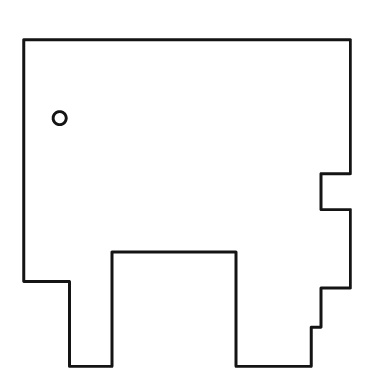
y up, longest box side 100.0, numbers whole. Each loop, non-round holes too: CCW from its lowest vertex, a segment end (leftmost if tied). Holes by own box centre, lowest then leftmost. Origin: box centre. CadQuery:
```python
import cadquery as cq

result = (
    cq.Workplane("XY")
    .moveTo(-36.0, -50.0)
    .lineTo(-23.0, -50.0)
    .lineTo(-23.0, -15.0)
    .lineTo(15.0, -15.0)
    .lineTo(15.0, -50.0)
    .lineTo(38.0, -50.0)
    .lineTo(38.0, -38.0)
    .lineTo(41.0, -38.0)
    .lineTo(41.0, -26.0)
    .lineTo(50.0, -26.0)
    .lineTo(50.0, -2.0)
    .lineTo(41.0, -2.0)
    .lineTo(41.0, 9.0)
    .lineTo(50.0, 9.0)
    .lineTo(50.0, 50.0)
    .lineTo(-50.0, 50.0)
    .lineTo(-50.0, -24.0)
    .lineTo(-36.0, -24.0)
    .close()
    .moveTo(-39.0, 26.0)
    .circle(2.0)
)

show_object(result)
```